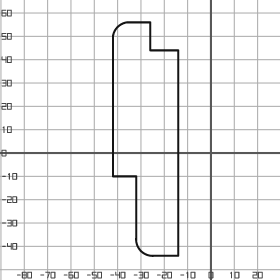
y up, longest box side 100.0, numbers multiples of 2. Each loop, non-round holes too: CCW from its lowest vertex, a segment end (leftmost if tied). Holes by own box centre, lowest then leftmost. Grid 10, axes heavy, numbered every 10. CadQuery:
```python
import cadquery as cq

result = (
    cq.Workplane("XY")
    .moveTo(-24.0, -44.0)
    .lineTo(-14.0, -44.0)
    .lineTo(-14.0, 44.0)
    .lineTo(-26.0, 44.0)
    .lineTo(-26.0, 56.0)
    .lineTo(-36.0, 56.0)
    .threePointArc((-40.0, 54.0), (-42.0, 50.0))
    .lineTo(-42.0, -10.0)
    .lineTo(-32.0, -10.0)
    .lineTo(-32.0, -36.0)
    .threePointArc((-30.0, -42.0), (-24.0, -44.0))
    .close()
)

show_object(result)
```